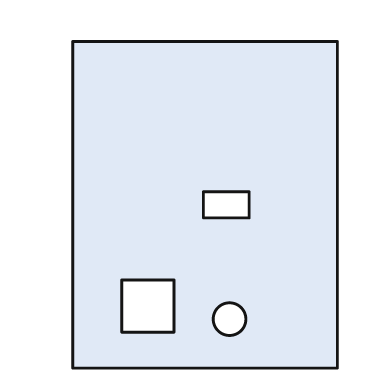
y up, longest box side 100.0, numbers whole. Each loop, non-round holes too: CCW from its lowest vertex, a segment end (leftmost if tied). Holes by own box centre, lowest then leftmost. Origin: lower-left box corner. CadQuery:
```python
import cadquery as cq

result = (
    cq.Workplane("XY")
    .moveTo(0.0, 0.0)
    .lineTo(81.0, 0.0)
    .lineTo(81.0, 100.0)
    .lineTo(0.0, 100.0)
    .close()
    .moveTo(48.0, 15.0)
    .circle(5.0)
    .moveTo(15.0, 11.0)
    .lineTo(31.0, 11.0)
    .lineTo(31.0, 27.0)
    .lineTo(15.0, 27.0)
    .close()
    .moveTo(40.0, 46.0)
    .lineTo(54.0, 46.0)
    .lineTo(54.0, 54.0)
    .lineTo(40.0, 54.0)
    .close()
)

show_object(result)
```